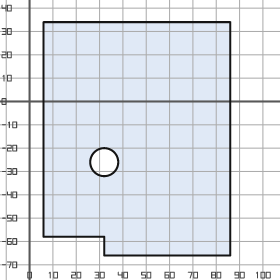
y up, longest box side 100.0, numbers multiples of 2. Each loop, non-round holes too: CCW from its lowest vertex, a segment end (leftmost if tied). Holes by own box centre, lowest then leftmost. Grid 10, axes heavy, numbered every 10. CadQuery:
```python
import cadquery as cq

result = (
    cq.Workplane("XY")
    .moveTo(32.0, -66.0)
    .lineTo(86.0, -66.0)
    .lineTo(86.0, 34.0)
    .lineTo(6.0, 34.0)
    .lineTo(6.0, -58.0)
    .lineTo(32.0, -58.0)
    .close()
    .moveTo(32.0, -26.0)
    .circle(6.0)
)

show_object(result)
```